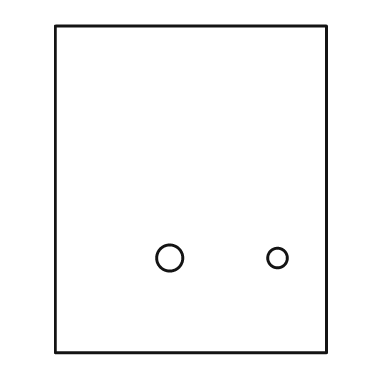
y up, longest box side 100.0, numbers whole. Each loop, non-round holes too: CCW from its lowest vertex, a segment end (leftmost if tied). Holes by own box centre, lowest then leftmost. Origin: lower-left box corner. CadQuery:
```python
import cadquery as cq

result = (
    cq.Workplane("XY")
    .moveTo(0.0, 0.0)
    .lineTo(83.0, 0.0)
    .lineTo(83.0, 100.0)
    .lineTo(0.0, 100.0)
    .close()
    .moveTo(35.0, 29.0)
    .circle(4.0)
    .moveTo(68.0, 29.0)
    .circle(3.0)
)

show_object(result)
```